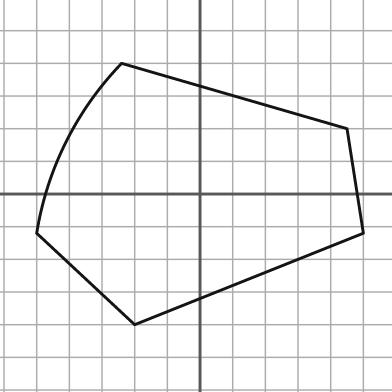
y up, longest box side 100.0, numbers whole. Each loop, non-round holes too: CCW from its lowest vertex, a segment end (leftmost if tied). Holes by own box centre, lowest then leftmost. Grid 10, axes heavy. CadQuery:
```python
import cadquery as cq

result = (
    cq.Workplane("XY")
    .moveTo(-20.0, -40.0)
    .lineTo(50.0, -12.0)
    .lineTo(45.0, 20.0)
    .lineTo(-24.0, 40.0)
    .threePointArc((-41.0, 16.0), (-50.0, -12.0))
    .close()
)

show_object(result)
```